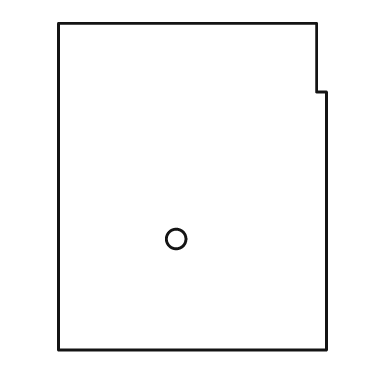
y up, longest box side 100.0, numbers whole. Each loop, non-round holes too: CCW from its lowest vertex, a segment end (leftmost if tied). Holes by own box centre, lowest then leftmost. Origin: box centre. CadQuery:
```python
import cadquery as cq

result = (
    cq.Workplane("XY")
    .moveTo(-41.0, -50.0)
    .lineTo(41.0, -50.0)
    .lineTo(41.0, 29.0)
    .lineTo(38.0, 29.0)
    .lineTo(38.0, 50.0)
    .lineTo(-41.0, 50.0)
    .close()
    .moveTo(-5.0, -16.0)
    .circle(3.0)
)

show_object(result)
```